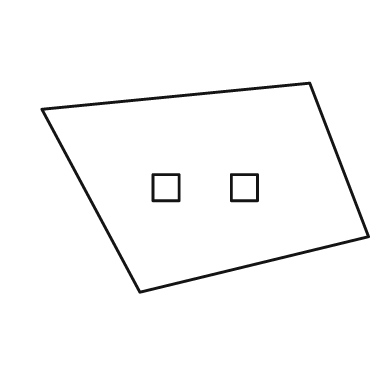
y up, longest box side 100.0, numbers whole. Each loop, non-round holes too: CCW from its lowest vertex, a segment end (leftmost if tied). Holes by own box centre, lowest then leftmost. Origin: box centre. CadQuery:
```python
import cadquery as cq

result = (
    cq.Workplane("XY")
    .moveTo(-20.0, -32.0)
    .lineTo(50.0, -15.0)
    .lineTo(32.0, 32.0)
    .lineTo(-50.0, 24.0)
    .close()
    .moveTo(-16.0, -4.0)
    .lineTo(-8.0, -4.0)
    .lineTo(-8.0, 4.0)
    .lineTo(-16.0, 4.0)
    .close()
    .moveTo(8.0, -4.0)
    .lineTo(16.0, -4.0)
    .lineTo(16.0, 4.0)
    .lineTo(8.0, 4.0)
    .close()
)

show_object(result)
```